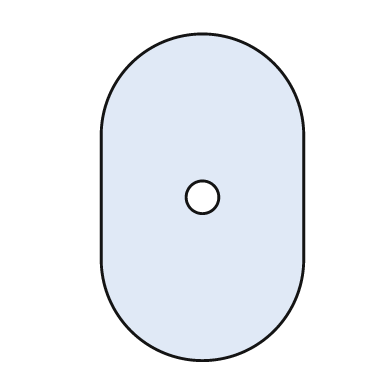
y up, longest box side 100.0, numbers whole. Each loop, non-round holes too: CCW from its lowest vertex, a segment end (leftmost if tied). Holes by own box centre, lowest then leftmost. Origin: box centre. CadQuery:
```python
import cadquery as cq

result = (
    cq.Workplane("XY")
    .moveTo(-31.0, -19.0)
    .threePointArc((0.0, -50.0), (31.0, -19.0))
    .lineTo(31.0, 19.0)
    .threePointArc((0.0, 50.0), (-31.0, 19.0))
    .close()
    .moveTo(0.0, 0.0)
    .circle(5.0)
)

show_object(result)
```